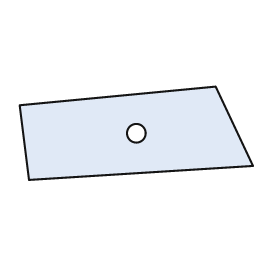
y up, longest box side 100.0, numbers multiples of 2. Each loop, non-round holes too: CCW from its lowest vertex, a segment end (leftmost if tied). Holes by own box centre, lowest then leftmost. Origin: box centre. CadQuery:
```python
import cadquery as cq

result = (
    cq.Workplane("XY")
    .moveTo(-46.0, -20.0)
    .lineTo(50.0, -14.0)
    .lineTo(34.0, 20.0)
    .lineTo(-50.0, 12.0)
    .close()
    .moveTo(0.0, 0.0)
    .circle(4.0)
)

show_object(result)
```